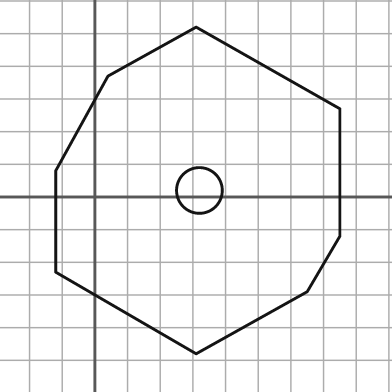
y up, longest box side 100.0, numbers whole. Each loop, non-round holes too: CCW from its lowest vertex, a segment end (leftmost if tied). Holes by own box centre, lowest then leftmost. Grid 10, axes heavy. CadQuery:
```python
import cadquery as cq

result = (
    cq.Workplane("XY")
    .moveTo(31.0, -48.0)
    .lineTo(65.0, -29.0)
    .lineTo(75.0, -12.0)
    .lineTo(75.0, 27.0)
    .lineTo(31.0, 52.0)
    .lineTo(4.0, 37.0)
    .lineTo(-12.0, 8.0)
    .lineTo(-12.0, -23.0)
    .close()
    .moveTo(32.0, 2.0)
    .circle(7.0)
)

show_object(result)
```